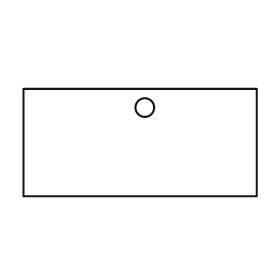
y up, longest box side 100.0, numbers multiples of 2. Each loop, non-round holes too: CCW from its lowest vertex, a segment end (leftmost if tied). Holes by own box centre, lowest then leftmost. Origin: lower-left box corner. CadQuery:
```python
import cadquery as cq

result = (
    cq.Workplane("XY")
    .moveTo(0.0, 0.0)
    .lineTo(100.0, 0.0)
    .lineTo(100.0, 46.0)
    .lineTo(0.0, 46.0)
    .close()
    .moveTo(52.0, 38.0)
    .circle(4.0)
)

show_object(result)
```